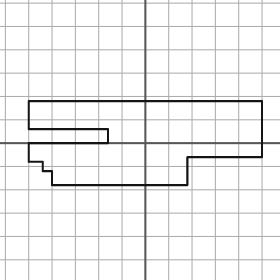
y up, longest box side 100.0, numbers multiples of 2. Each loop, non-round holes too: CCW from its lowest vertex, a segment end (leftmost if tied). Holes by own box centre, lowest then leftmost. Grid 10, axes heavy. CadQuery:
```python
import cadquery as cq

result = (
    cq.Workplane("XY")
    .moveTo(-40.0, -18.0)
    .lineTo(18.0, -18.0)
    .lineTo(18.0, -6.0)
    .lineTo(50.0, -6.0)
    .lineTo(50.0, 18.0)
    .lineTo(-50.0, 18.0)
    .lineTo(-50.0, 6.0)
    .lineTo(-16.0, 6.0)
    .lineTo(-16.0, 0.0)
    .lineTo(-50.0, 0.0)
    .lineTo(-50.0, -8.0)
    .lineTo(-44.0, -8.0)
    .lineTo(-44.0, -12.0)
    .lineTo(-40.0, -12.0)
    .close()
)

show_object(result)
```